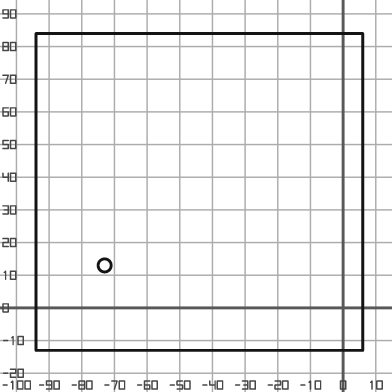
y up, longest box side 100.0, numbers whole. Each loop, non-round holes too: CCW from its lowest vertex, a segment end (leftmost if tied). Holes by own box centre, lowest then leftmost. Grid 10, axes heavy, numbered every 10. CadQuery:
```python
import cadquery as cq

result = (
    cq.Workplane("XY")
    .moveTo(-94.0, -13.0)
    .lineTo(6.0, -13.0)
    .lineTo(6.0, 84.0)
    .lineTo(-94.0, 84.0)
    .close()
    .moveTo(-73.0, 13.0)
    .circle(2.0)
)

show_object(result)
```